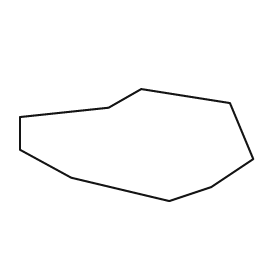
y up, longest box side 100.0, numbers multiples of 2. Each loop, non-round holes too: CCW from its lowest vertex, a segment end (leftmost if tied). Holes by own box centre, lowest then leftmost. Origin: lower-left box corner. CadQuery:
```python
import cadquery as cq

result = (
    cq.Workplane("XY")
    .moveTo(64.0, 0.0)
    .lineTo(82.0, 6.0)
    .lineTo(100.0, 18.0)
    .lineTo(90.0, 42.0)
    .lineTo(52.0, 48.0)
    .lineTo(38.0, 40.0)
    .lineTo(0.0, 36.0)
    .lineTo(0.0, 22.0)
    .lineTo(22.0, 10.0)
    .close()
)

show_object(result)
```